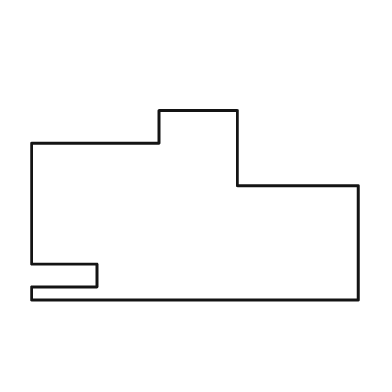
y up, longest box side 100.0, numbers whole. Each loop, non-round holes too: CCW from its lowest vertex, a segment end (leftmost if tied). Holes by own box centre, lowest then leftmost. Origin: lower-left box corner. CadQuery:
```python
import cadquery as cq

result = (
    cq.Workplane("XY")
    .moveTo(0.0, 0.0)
    .lineTo(100.0, 0.0)
    .lineTo(100.0, 35.0)
    .lineTo(63.0, 35.0)
    .lineTo(63.0, 58.0)
    .lineTo(39.0, 58.0)
    .lineTo(39.0, 48.0)
    .lineTo(0.0, 48.0)
    .lineTo(0.0, 11.0)
    .lineTo(20.0, 11.0)
    .lineTo(20.0, 4.0)
    .lineTo(0.0, 4.0)
    .close()
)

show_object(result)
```